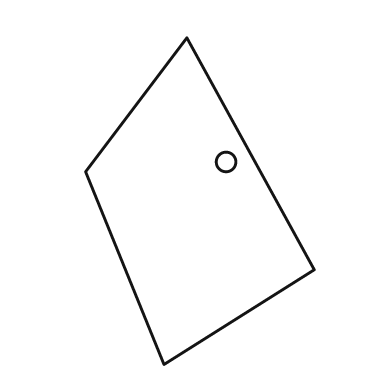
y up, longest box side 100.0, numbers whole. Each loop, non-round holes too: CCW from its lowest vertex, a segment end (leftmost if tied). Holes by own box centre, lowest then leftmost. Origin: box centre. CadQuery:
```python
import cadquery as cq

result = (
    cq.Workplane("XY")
    .moveTo(-11.0, -50.0)
    .lineTo(35.0, -21.0)
    .lineTo(-4.0, 50.0)
    .lineTo(-35.0, 9.0)
    .close()
    .moveTo(8.0, 12.0)
    .circle(3.0)
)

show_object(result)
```